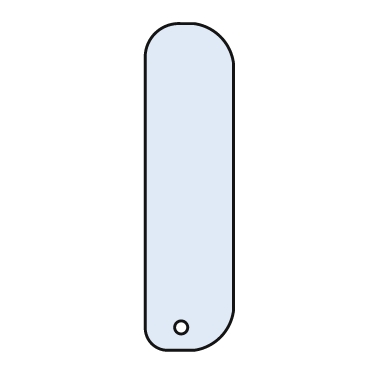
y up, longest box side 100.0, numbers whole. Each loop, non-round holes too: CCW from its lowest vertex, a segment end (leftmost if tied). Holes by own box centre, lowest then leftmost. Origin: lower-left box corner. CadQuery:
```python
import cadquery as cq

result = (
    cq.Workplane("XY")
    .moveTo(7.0, 0.0)
    .lineTo(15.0, 0.0)
    .threePointArc((23.0, 4.0), (27.0, 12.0))
    .lineTo(27.0, 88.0)
    .threePointArc((23.0, 96.0), (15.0, 100.0))
    .lineTo(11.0, 100.0)
    .threePointArc((3.0, 97.0), (0.0, 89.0))
    .lineTo(0.0, 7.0)
    .threePointArc((2.0, 2.0), (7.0, 0.0))
    .close()
    .moveTo(11.0, 7.0)
    .circle(2.0)
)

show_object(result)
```